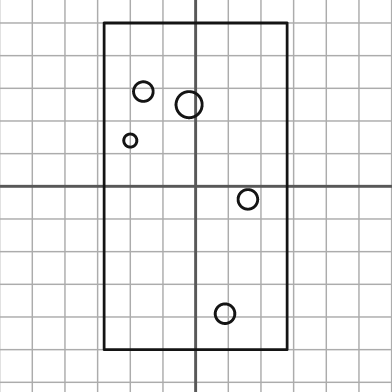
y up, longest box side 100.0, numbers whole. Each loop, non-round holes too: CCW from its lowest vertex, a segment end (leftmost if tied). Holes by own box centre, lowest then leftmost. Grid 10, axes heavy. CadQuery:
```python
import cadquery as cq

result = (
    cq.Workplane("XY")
    .moveTo(-28.0, -50.0)
    .lineTo(28.0, -50.0)
    .lineTo(28.0, 50.0)
    .lineTo(-28.0, 50.0)
    .close()
    .moveTo(9.0, -39.0)
    .circle(3.0)
    .moveTo(16.0, -4.0)
    .circle(3.0)
    .moveTo(-20.0, 14.0)
    .circle(2.0)
    .moveTo(-2.0, 25.0)
    .circle(4.0)
    .moveTo(-16.0, 29.0)
    .circle(3.0)
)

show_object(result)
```